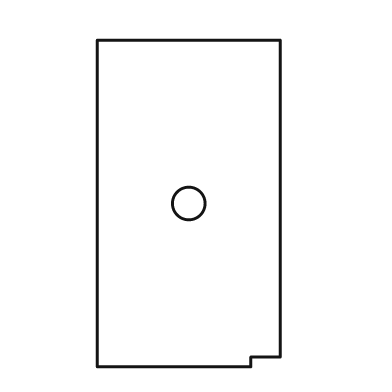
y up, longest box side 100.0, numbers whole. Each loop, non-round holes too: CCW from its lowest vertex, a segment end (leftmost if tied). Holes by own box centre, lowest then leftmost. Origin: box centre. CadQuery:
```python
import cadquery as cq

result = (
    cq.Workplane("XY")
    .moveTo(-28.0, -50.0)
    .lineTo(19.0, -50.0)
    .lineTo(19.0, -47.0)
    .lineTo(28.0, -47.0)
    .lineTo(28.0, 50.0)
    .lineTo(-28.0, 50.0)
    .close()
    .moveTo(0.0, 0.0)
    .circle(5.0)
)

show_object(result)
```